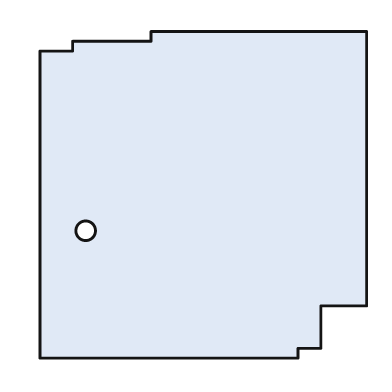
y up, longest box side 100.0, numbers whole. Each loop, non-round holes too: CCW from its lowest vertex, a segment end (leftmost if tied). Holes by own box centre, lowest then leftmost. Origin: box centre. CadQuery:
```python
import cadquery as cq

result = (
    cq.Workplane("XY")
    .moveTo(-50.0, -50.0)
    .lineTo(29.0, -50.0)
    .lineTo(29.0, -47.0)
    .lineTo(36.0, -47.0)
    .lineTo(36.0, -34.0)
    .lineTo(50.0, -34.0)
    .lineTo(50.0, 50.0)
    .lineTo(-16.0, 50.0)
    .lineTo(-16.0, 47.0)
    .lineTo(-40.0, 47.0)
    .lineTo(-40.0, 44.0)
    .lineTo(-50.0, 44.0)
    .close()
    .moveTo(-36.0, -11.0)
    .circle(3.0)
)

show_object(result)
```